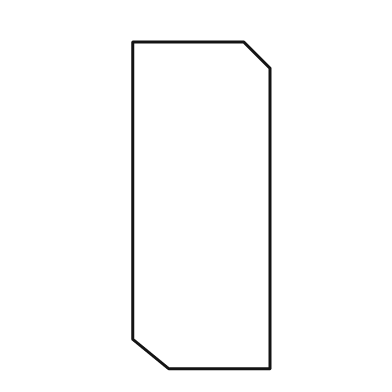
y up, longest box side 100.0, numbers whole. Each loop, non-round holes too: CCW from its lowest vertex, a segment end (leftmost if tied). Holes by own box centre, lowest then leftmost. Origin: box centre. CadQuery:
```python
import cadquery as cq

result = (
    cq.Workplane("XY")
    .moveTo(-10.0, -50.0)
    .lineTo(21.0, -50.0)
    .lineTo(21.0, 42.0)
    .lineTo(13.0, 50.0)
    .lineTo(-21.0, 50.0)
    .lineTo(-21.0, -41.0)
    .close()
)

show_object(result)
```